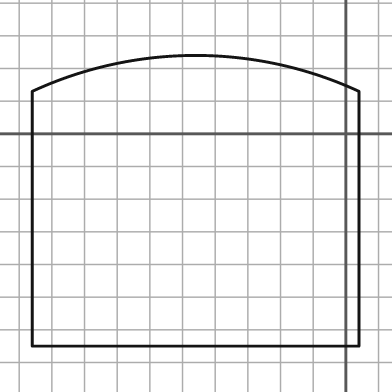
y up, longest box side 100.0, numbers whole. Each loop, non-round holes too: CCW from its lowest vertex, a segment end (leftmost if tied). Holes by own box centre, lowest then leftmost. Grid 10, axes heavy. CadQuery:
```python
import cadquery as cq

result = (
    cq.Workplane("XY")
    .moveTo(-96.0, -65.0)
    .lineTo(4.0, -65.0)
    .lineTo(4.0, 13.0)
    .threePointArc((-46.0, 24.0), (-96.0, 13.0))
    .close()
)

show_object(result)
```